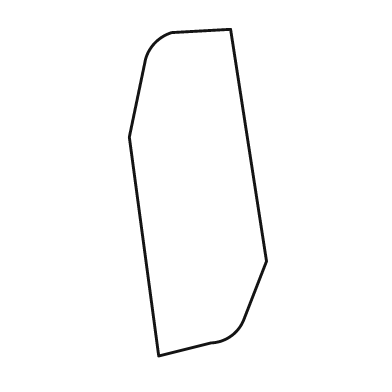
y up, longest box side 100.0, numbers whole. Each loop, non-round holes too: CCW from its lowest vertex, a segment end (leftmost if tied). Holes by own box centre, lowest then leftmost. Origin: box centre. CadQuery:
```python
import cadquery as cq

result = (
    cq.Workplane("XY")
    .moveTo(-12.0, -50.0)
    .lineTo(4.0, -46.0)
    .threePointArc((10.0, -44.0), (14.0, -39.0))
    .lineTo(21.0, -21.0)
    .lineTo(10.0, 50.0)
    .lineTo(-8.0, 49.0)
    .threePointArc((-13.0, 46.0), (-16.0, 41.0))
    .lineTo(-21.0, 17.0)
    .close()
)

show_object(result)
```